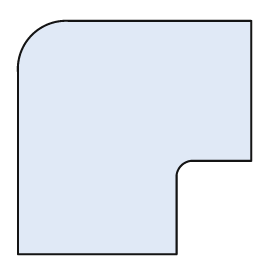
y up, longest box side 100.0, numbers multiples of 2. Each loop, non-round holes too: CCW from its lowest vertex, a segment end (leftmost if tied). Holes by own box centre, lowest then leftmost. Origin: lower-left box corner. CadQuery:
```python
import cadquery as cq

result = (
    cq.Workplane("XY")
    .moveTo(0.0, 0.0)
    .lineTo(68.0, 0.0)
    .lineTo(68.0, 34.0)
    .threePointArc((70.0, 38.0), (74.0, 40.0))
    .lineTo(100.0, 40.0)
    .lineTo(100.0, 100.0)
    .lineTo(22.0, 100.0)
    .threePointArc((6.0, 94.0), (0.0, 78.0))
    .close()
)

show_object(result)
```